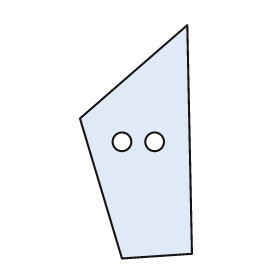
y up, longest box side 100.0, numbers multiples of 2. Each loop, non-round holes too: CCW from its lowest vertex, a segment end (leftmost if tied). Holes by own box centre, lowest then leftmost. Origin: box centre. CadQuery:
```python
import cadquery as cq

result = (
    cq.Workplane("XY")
    .moveTo(-6.0, -50.0)
    .lineTo(24.0, -48.0)
    .lineTo(22.0, 50.0)
    .lineTo(-24.0, 10.0)
    .close()
    .moveTo(-6.0, 0.0)
    .circle(4.0)
    .moveTo(8.0, 0.0)
    .circle(4.0)
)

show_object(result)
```